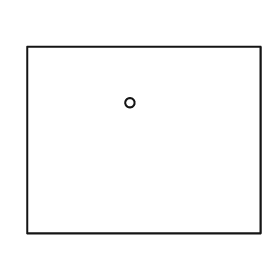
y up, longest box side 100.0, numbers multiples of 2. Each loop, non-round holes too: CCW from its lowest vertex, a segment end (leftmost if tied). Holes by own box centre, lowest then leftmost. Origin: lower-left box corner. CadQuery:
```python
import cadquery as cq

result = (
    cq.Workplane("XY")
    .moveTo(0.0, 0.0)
    .lineTo(100.0, 0.0)
    .lineTo(100.0, 80.0)
    .lineTo(0.0, 80.0)
    .close()
    .moveTo(44.0, 56.0)
    .circle(2.0)
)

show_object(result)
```